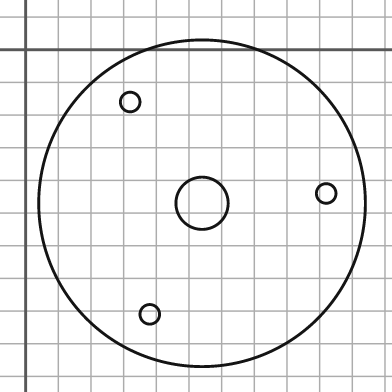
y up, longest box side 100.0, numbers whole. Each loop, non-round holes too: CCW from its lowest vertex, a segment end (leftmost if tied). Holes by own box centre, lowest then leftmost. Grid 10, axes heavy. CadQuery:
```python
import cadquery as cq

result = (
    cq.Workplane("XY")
    .moveTo(54.0, -47.0)
    .circle(50.0)
    .moveTo(38.0, -81.0)
    .circle(3.0)
    .moveTo(54.0, -47.0)
    .circle(8.0)
    .moveTo(92.0, -44.0)
    .circle(3.0)
    .moveTo(32.0, -16.0)
    .circle(3.0)
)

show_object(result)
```